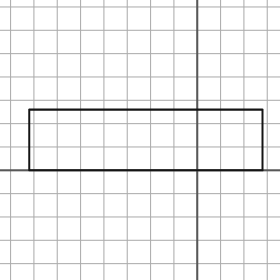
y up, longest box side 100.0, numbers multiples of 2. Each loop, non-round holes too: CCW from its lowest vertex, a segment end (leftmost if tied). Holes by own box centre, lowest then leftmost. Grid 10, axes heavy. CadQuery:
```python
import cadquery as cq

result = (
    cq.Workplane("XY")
    .moveTo(-72.0, 0.0)
    .lineTo(28.0, 0.0)
    .lineTo(28.0, 26.0)
    .lineTo(-72.0, 26.0)
    .close()
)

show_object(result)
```